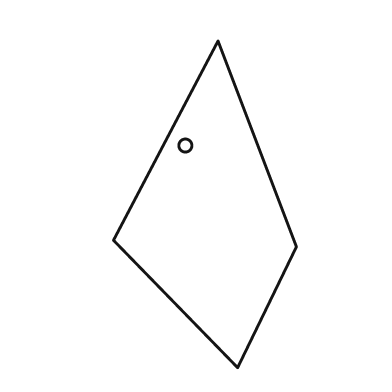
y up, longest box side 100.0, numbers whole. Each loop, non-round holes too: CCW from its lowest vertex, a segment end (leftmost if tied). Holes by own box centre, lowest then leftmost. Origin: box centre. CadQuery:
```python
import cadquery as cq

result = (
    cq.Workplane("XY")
    .moveTo(10.0, -50.0)
    .lineTo(28.0, -13.0)
    .lineTo(4.0, 50.0)
    .lineTo(-28.0, -11.0)
    .close()
    .moveTo(-6.0, 18.0)
    .circle(2.0)
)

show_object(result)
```